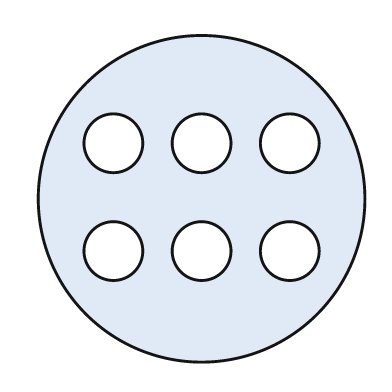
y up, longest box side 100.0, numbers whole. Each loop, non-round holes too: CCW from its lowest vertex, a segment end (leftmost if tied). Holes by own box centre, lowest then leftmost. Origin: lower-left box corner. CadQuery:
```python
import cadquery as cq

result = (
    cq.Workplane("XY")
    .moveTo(50.0, 50.0)
    .circle(50.0)
    .moveTo(23.0, 34.0)
    .circle(9.0)
    .moveTo(50.0, 34.0)
    .circle(9.0)
    .moveTo(77.0, 34.0)
    .circle(9.0)
    .moveTo(23.0, 67.0)
    .circle(9.0)
    .moveTo(50.0, 67.0)
    .circle(9.0)
    .moveTo(77.0, 67.0)
    .circle(9.0)
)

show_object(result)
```